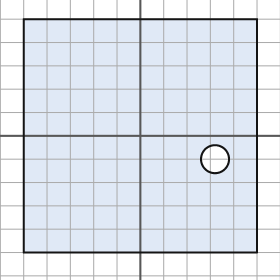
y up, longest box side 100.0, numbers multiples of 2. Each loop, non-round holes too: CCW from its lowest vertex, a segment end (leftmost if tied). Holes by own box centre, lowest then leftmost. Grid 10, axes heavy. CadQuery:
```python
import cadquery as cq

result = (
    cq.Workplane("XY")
    .moveTo(-50.0, -50.0)
    .lineTo(50.0, -50.0)
    .lineTo(50.0, 50.0)
    .lineTo(-50.0, 50.0)
    .close()
    .moveTo(32.0, -10.0)
    .circle(6.0)
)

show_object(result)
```